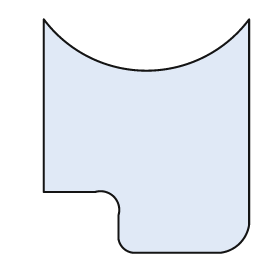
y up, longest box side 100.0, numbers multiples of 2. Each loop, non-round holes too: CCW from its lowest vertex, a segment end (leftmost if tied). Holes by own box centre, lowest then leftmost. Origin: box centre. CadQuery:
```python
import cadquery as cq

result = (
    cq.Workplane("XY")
    .moveTo(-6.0, -50.0)
    .lineTo(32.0, -50.0)
    .threePointArc((40.0, -46.0), (44.0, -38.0))
    .lineTo(44.0, 50.0)
    .threePointArc((0.0, 28.0), (-44.0, 50.0))
    .lineTo(-44.0, -24.0)
    .lineTo(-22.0, -24.0)
    .threePointArc((-14.0, -26.0), (-12.0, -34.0))
    .lineTo(-12.0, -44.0)
    .threePointArc((-10.0, -48.0), (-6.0, -50.0))
    .close()
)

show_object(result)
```